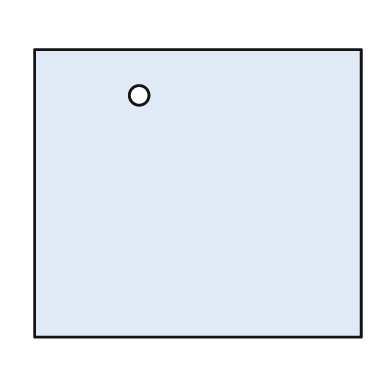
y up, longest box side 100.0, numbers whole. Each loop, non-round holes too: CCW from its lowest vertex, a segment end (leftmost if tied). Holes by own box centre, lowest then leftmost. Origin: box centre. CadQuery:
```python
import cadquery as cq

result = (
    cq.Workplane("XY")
    .moveTo(-50.0, -44.0)
    .lineTo(50.0, -44.0)
    .lineTo(50.0, 44.0)
    .lineTo(-50.0, 44.0)
    .close()
    .moveTo(-18.0, 30.0)
    .circle(3.0)
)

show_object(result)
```